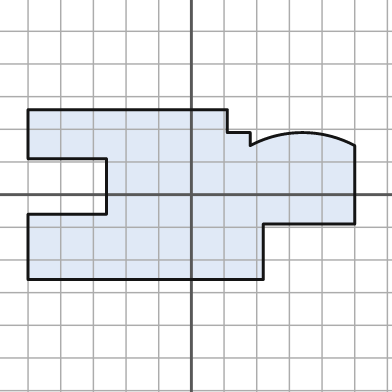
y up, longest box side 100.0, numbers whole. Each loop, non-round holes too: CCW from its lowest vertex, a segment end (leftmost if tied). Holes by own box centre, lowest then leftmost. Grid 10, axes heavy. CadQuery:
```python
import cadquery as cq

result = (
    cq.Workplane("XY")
    .moveTo(-50.0, -26.0)
    .lineTo(22.0, -26.0)
    .lineTo(22.0, -9.0)
    .lineTo(50.0, -9.0)
    .lineTo(50.0, 15.0)
    .threePointArc((34.0, 19.0), (18.0, 15.0))
    .lineTo(18.0, 19.0)
    .lineTo(11.0, 19.0)
    .lineTo(11.0, 26.0)
    .lineTo(-50.0, 26.0)
    .lineTo(-50.0, 11.0)
    .lineTo(-26.0, 11.0)
    .lineTo(-26.0, -6.0)
    .lineTo(-50.0, -6.0)
    .close()
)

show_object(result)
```